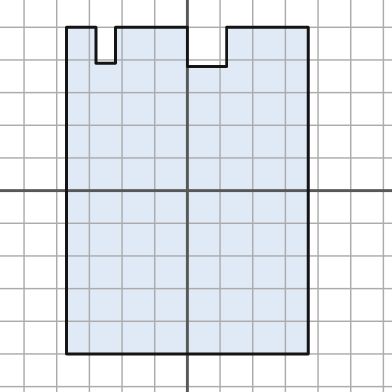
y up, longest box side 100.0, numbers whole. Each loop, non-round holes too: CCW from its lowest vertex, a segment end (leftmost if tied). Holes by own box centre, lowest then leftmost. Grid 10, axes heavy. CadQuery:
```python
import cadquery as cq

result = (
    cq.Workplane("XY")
    .moveTo(-37.0, -50.0)
    .lineTo(37.0, -50.0)
    .lineTo(37.0, 50.0)
    .lineTo(12.0, 50.0)
    .lineTo(12.0, 38.0)
    .lineTo(0.0, 38.0)
    .lineTo(0.0, 50.0)
    .lineTo(-22.0, 50.0)
    .lineTo(-22.0, 39.0)
    .lineTo(-28.0, 39.0)
    .lineTo(-28.0, 50.0)
    .lineTo(-37.0, 50.0)
    .close()
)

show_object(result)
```